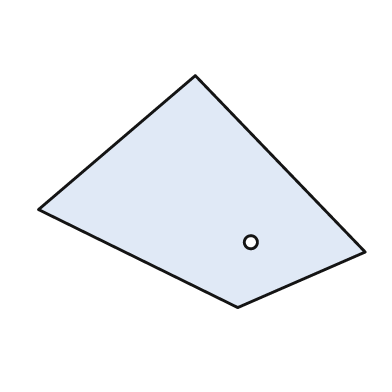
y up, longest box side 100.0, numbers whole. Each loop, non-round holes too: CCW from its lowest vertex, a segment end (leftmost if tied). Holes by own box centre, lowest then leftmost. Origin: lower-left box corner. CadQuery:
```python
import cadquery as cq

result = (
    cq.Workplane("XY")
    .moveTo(61.0, 0.0)
    .lineTo(100.0, 17.0)
    .lineTo(48.0, 71.0)
    .lineTo(0.0, 30.0)
    .close()
    .moveTo(65.0, 20.0)
    .circle(2.0)
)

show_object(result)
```